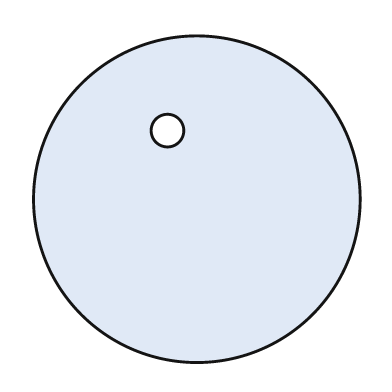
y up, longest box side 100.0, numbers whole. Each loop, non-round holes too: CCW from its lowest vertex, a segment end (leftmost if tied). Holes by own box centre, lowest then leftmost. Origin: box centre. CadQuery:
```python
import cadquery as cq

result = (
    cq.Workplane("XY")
    .moveTo(0.0, 0.0)
    .circle(50.0)
    .moveTo(-9.0, 21.0)
    .circle(5.0)
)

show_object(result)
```